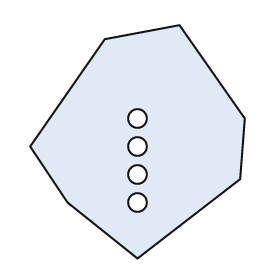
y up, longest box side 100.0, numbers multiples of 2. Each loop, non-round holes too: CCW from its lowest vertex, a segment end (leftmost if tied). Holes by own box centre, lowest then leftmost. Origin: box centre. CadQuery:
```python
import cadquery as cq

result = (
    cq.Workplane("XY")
    .moveTo(0.0, -50.0)
    .lineTo(44.0, -16.0)
    .lineTo(46.0, 10.0)
    .lineTo(18.0, 50.0)
    .lineTo(-14.0, 44.0)
    .lineTo(-46.0, -2.0)
    .lineTo(-30.0, -26.0)
    .close()
    .moveTo(0.0, -26.0)
    .circle(4.0)
    .moveTo(0.0, -14.0)
    .circle(4.0)
    .moveTo(0.0, -2.0)
    .circle(4.0)
    .moveTo(0.0, 10.0)
    .circle(4.0)
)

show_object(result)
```